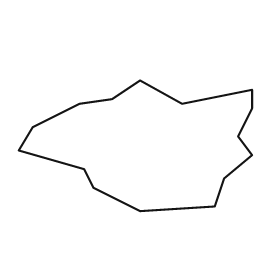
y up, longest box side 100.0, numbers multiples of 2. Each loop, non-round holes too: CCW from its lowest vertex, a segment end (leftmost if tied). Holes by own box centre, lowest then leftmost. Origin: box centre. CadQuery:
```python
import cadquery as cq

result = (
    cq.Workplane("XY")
    .moveTo(2.0, -28.0)
    .lineTo(34.0, -26.0)
    .lineTo(38.0, -14.0)
    .lineTo(50.0, -4.0)
    .lineTo(44.0, 4.0)
    .lineTo(50.0, 16.0)
    .lineTo(50.0, 24.0)
    .lineTo(20.0, 18.0)
    .lineTo(2.0, 28.0)
    .lineTo(-10.0, 20.0)
    .lineTo(-24.0, 18.0)
    .lineTo(-44.0, 8.0)
    .lineTo(-50.0, -2.0)
    .lineTo(-22.0, -10.0)
    .lineTo(-18.0, -18.0)
    .close()
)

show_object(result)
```